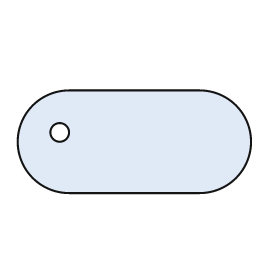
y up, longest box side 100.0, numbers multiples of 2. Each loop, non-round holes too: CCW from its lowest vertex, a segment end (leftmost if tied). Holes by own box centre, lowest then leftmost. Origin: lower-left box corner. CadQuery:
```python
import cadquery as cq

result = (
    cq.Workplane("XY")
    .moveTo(22.0, 0.0)
    .lineTo(78.0, 0.0)
    .threePointArc((100.0, 22.0), (78.0, 44.0))
    .lineTo(22.0, 44.0)
    .threePointArc((0.0, 22.0), (22.0, 0.0))
    .close()
    .moveTo(18.0, 26.0)
    .circle(4.0)
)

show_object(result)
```